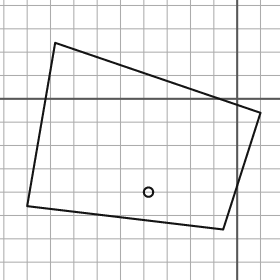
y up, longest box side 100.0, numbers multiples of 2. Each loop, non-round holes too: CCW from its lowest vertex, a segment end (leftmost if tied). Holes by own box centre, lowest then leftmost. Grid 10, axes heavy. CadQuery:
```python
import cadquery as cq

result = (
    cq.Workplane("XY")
    .moveTo(-6.0, -56.0)
    .lineTo(10.0, -6.0)
    .lineTo(-78.0, 24.0)
    .lineTo(-90.0, -46.0)
    .close()
    .moveTo(-38.0, -40.0)
    .circle(2.0)
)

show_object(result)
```